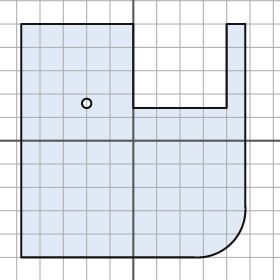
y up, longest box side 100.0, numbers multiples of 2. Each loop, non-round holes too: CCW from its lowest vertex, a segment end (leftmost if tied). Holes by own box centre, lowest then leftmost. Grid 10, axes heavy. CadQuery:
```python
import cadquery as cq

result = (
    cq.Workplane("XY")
    .moveTo(-48.0, -50.0)
    .lineTo(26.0, -50.0)
    .threePointArc((42.0, -44.0), (48.0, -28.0))
    .lineTo(48.0, 50.0)
    .lineTo(40.0, 50.0)
    .lineTo(40.0, 14.0)
    .lineTo(0.0, 14.0)
    .lineTo(0.0, 50.0)
    .lineTo(-48.0, 50.0)
    .close()
    .moveTo(-20.0, 16.0)
    .circle(2.0)
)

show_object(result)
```